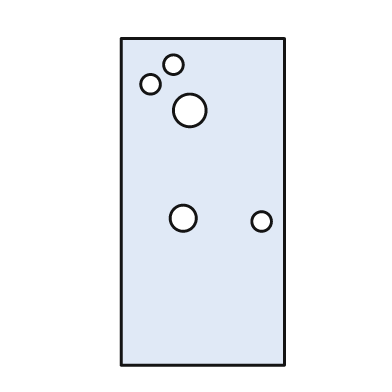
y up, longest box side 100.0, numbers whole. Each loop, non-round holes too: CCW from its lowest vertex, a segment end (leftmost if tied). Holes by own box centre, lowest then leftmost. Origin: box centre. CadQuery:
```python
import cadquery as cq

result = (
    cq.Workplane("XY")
    .moveTo(-25.0, -50.0)
    .lineTo(25.0, -50.0)
    .lineTo(25.0, 50.0)
    .lineTo(-25.0, 50.0)
    .close()
    .moveTo(18.0, -6.0)
    .circle(3.0)
    .moveTo(-6.0, -5.0)
    .circle(4.0)
    .moveTo(-4.0, 28.0)
    .circle(5.0)
    .moveTo(-16.0, 36.0)
    .circle(3.0)
    .moveTo(-9.0, 42.0)
    .circle(3.0)
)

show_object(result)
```